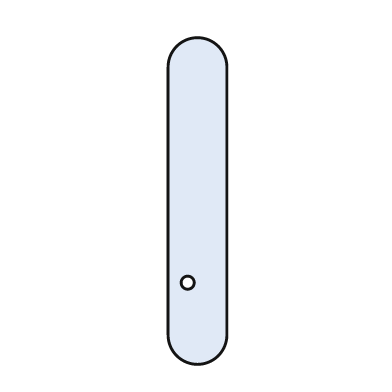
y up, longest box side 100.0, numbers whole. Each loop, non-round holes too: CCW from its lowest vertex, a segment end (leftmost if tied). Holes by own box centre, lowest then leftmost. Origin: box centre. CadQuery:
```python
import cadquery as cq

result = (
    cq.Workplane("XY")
    .moveTo(-9.0, -41.0)
    .threePointArc((0.0, -50.0), (9.0, -41.0))
    .lineTo(9.0, 41.0)
    .threePointArc((0.0, 50.0), (-9.0, 41.0))
    .close()
    .moveTo(-3.0, -25.0)
    .circle(2.0)
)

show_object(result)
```